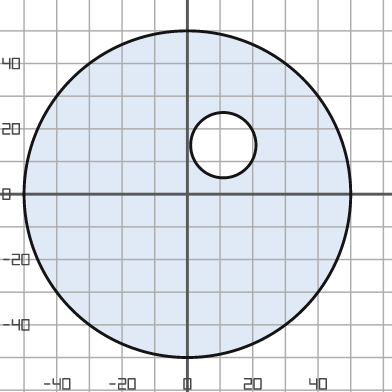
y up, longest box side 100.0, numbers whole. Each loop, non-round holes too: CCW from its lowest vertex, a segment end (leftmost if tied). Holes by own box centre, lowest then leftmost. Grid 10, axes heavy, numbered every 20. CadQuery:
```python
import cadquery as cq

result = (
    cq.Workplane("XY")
    .moveTo(0.0, 0.0)
    .circle(50.0)
    .moveTo(11.0, 15.0)
    .circle(10.0)
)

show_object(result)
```